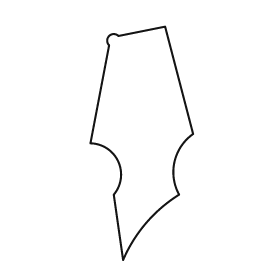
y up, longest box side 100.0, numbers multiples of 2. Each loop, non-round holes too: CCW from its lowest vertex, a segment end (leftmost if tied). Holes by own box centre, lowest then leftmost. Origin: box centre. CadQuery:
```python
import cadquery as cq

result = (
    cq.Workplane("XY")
    .moveTo(-8.0, -50.0)
    .threePointArc((2.0, -34.0), (16.0, -22.0))
    .threePointArc((14.0, -8.0), (22.0, 4.0))
    .lineTo(10.0, 50.0)
    .lineTo(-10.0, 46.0)
    .threePointArc((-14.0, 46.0), (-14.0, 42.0))
    .lineTo(-22.0, 0.0)
    .threePointArc((-10.0, -8.0), (-12.0, -22.0))
    .close()
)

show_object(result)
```